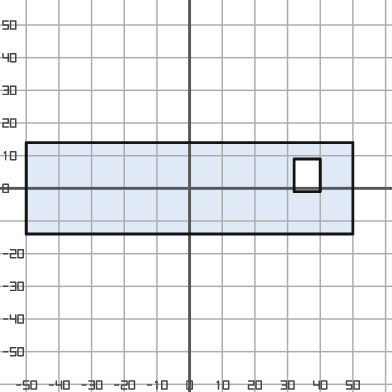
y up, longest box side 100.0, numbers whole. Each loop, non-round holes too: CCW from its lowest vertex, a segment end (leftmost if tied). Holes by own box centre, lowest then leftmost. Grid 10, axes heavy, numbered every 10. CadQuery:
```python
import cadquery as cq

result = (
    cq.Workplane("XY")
    .moveTo(-50.0, -14.0)
    .lineTo(50.0, -14.0)
    .lineTo(50.0, 14.0)
    .lineTo(-50.0, 14.0)
    .close()
    .moveTo(32.0, -1.0)
    .lineTo(40.0, -1.0)
    .lineTo(40.0, 9.0)
    .lineTo(32.0, 9.0)
    .close()
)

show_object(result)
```